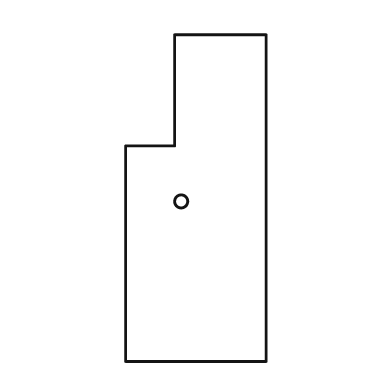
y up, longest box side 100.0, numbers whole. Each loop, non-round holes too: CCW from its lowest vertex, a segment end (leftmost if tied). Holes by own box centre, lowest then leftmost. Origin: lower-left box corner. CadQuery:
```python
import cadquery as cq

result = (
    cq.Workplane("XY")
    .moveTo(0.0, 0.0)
    .lineTo(43.0, 0.0)
    .lineTo(43.0, 100.0)
    .lineTo(15.0, 100.0)
    .lineTo(15.0, 66.0)
    .lineTo(0.0, 66.0)
    .close()
    .moveTo(17.0, 49.0)
    .circle(2.0)
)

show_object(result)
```